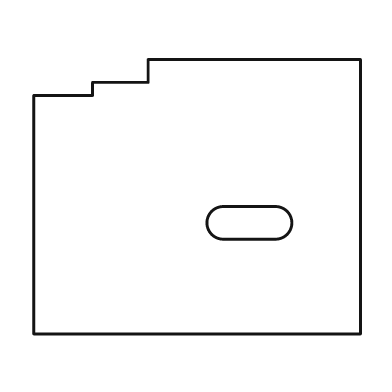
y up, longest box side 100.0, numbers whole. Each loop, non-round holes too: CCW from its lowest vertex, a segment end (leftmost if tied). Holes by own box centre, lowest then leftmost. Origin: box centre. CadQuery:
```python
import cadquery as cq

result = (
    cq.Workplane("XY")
    .moveTo(-50.0, -42.0)
    .lineTo(50.0, -42.0)
    .lineTo(50.0, 42.0)
    .lineTo(-15.0, 42.0)
    .lineTo(-15.0, 35.0)
    .lineTo(-32.0, 35.0)
    .lineTo(-32.0, 31.0)
    .lineTo(-50.0, 31.0)
    .close()
    .moveTo(8.0, -13.0)
    .lineTo(24.0, -13.0)
    .threePointArc((29.0, -8.0), (24.0, -3.0))
    .lineTo(8.0, -3.0)
    .threePointArc((3.0, -8.0), (8.0, -13.0))
    .close()
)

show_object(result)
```